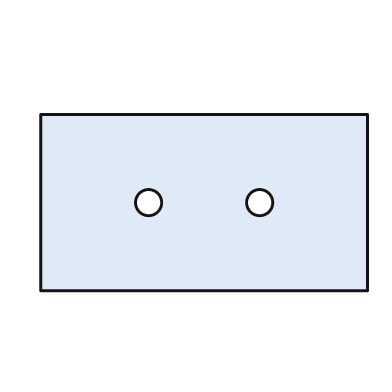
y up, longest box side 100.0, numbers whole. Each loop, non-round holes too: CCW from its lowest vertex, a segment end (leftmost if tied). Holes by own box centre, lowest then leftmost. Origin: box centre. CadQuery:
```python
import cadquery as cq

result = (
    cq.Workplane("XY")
    .moveTo(-50.0, -27.0)
    .lineTo(50.0, -27.0)
    .lineTo(50.0, 27.0)
    .lineTo(-50.0, 27.0)
    .close()
    .moveTo(-17.0, 0.0)
    .circle(4.0)
    .moveTo(17.0, 0.0)
    .circle(4.0)
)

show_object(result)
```